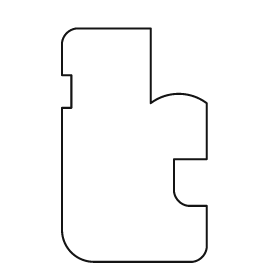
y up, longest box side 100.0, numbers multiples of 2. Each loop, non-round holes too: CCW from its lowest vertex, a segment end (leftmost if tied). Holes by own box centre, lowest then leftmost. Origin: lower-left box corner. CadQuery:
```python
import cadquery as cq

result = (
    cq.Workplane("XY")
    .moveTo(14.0, 0.0)
    .lineTo(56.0, 0.0)
    .threePointArc((60.0, 2.0), (62.0, 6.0))
    .lineTo(62.0, 24.0)
    .lineTo(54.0, 24.0)
    .threePointArc((50.0, 26.0), (48.0, 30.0))
    .lineTo(48.0, 44.0)
    .lineTo(62.0, 44.0)
    .lineTo(62.0, 68.0)
    .threePointArc((50.0, 72.0), (38.0, 68.0))
    .lineTo(38.0, 100.0)
    .lineTo(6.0, 100.0)
    .threePointArc((2.0, 98.0), (0.0, 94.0))
    .lineTo(0.0, 80.0)
    .lineTo(4.0, 80.0)
    .lineTo(4.0, 66.0)
    .lineTo(0.0, 66.0)
    .lineTo(0.0, 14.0)
    .threePointArc((4.0, 4.0), (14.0, 0.0))
    .close()
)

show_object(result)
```